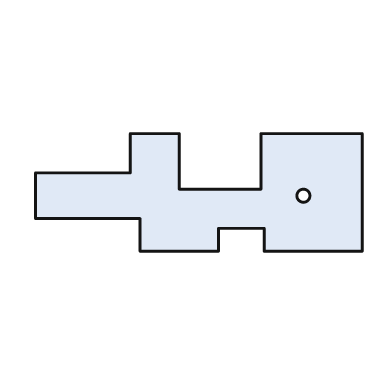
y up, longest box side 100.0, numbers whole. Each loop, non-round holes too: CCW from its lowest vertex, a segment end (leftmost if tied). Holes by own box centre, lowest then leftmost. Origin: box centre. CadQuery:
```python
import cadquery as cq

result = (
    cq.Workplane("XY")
    .moveTo(-18.0, -18.0)
    .lineTo(6.0, -18.0)
    .lineTo(6.0, -11.0)
    .lineTo(20.0, -11.0)
    .lineTo(20.0, -18.0)
    .lineTo(50.0, -18.0)
    .lineTo(50.0, 18.0)
    .lineTo(19.0, 18.0)
    .lineTo(19.0, 1.0)
    .lineTo(-6.0, 1.0)
    .lineTo(-6.0, 18.0)
    .lineTo(-21.0, 18.0)
    .lineTo(-21.0, 6.0)
    .lineTo(-50.0, 6.0)
    .lineTo(-50.0, -8.0)
    .lineTo(-18.0, -8.0)
    .close()
    .moveTo(32.0, -1.0)
    .circle(2.0)
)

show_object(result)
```